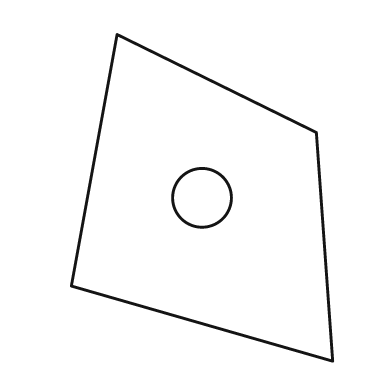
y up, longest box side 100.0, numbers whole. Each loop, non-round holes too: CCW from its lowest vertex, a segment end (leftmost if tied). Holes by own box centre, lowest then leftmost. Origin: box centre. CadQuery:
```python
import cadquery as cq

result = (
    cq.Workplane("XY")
    .moveTo(40.0, -50.0)
    .lineTo(35.0, 20.0)
    .lineTo(-26.0, 50.0)
    .lineTo(-40.0, -27.0)
    .close()
    .moveTo(0.0, 0.0)
    .circle(9.0)
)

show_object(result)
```